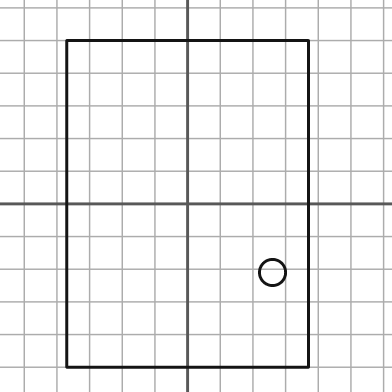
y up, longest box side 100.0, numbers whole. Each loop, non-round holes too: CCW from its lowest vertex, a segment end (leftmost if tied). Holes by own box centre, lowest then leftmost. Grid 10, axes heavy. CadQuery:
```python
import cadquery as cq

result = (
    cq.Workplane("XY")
    .moveTo(-37.0, -50.0)
    .lineTo(37.0, -50.0)
    .lineTo(37.0, 50.0)
    .lineTo(-37.0, 50.0)
    .close()
    .moveTo(26.0, -21.0)
    .circle(4.0)
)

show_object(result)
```